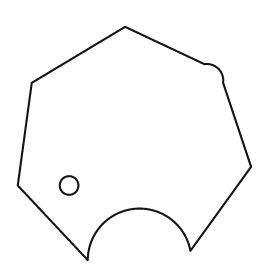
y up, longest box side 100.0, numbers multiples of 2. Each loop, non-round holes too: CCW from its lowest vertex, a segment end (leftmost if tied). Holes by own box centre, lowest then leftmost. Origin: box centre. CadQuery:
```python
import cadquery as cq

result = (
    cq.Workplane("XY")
    .moveTo(-20.0, -50.0)
    .threePointArc((0.0, -28.0), (24.0, -46.0))
    .lineTo(50.0, -10.0)
    .lineTo(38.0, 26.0)
    .threePointArc((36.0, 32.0), (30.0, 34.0))
    .lineTo(-4.0, 50.0)
    .lineTo(-44.0, 26.0)
    .lineTo(-50.0, -18.0)
    .close()
    .moveTo(-28.0, -18.0)
    .circle(4.0)
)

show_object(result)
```